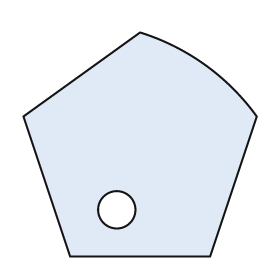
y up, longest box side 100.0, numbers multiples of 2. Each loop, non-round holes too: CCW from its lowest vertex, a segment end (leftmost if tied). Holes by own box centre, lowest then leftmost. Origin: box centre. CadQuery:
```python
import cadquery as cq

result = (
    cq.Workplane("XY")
    .moveTo(-30.0, -48.0)
    .lineTo(30.0, -48.0)
    .lineTo(50.0, 12.0)
    .threePointArc((28.0, 34.0), (0.0, 48.0))
    .lineTo(-50.0, 12.0)
    .close()
    .moveTo(-10.0, -28.0)
    .circle(8.0)
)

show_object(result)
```